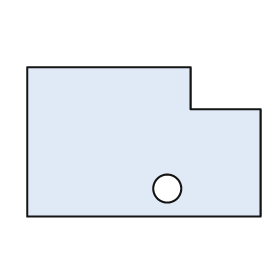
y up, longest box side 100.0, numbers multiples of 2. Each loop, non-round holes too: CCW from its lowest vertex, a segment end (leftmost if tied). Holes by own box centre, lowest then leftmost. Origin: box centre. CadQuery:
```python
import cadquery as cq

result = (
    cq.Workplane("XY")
    .moveTo(-50.0, -32.0)
    .lineTo(50.0, -32.0)
    .lineTo(50.0, 14.0)
    .lineTo(20.0, 14.0)
    .lineTo(20.0, 32.0)
    .lineTo(-50.0, 32.0)
    .close()
    .moveTo(10.0, -20.0)
    .circle(6.0)
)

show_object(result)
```